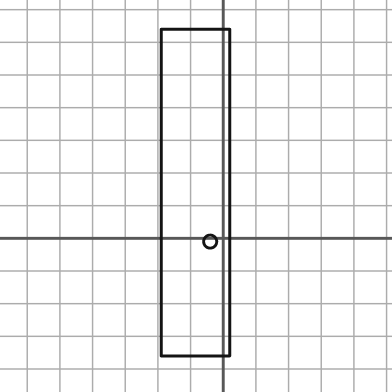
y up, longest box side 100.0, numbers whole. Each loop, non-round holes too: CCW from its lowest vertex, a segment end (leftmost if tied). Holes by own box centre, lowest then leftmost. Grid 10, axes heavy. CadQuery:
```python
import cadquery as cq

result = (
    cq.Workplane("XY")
    .moveTo(-19.0, -36.0)
    .lineTo(2.0, -36.0)
    .lineTo(2.0, 64.0)
    .lineTo(-19.0, 64.0)
    .close()
    .moveTo(-4.0, -1.0)
    .circle(2.0)
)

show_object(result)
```